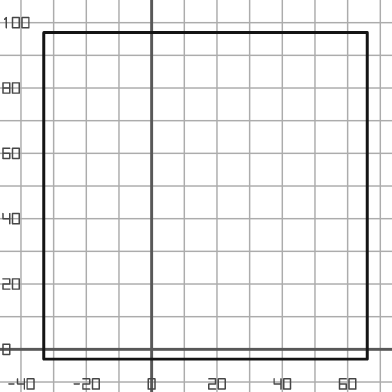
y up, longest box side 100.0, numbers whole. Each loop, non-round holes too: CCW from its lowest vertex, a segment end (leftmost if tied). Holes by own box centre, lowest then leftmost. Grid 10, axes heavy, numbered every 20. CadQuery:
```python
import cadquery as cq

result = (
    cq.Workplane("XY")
    .moveTo(-33.0, -3.0)
    .lineTo(66.0, -3.0)
    .lineTo(66.0, 97.0)
    .lineTo(-33.0, 97.0)
    .close()
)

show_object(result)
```